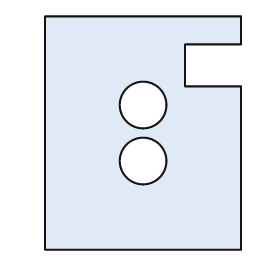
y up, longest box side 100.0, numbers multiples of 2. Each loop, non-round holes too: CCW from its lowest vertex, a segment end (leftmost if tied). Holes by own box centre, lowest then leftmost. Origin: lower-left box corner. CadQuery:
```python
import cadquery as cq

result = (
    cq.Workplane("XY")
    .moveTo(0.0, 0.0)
    .lineTo(84.0, 0.0)
    .lineTo(84.0, 70.0)
    .lineTo(60.0, 70.0)
    .lineTo(60.0, 88.0)
    .lineTo(84.0, 88.0)
    .lineTo(84.0, 100.0)
    .lineTo(0.0, 100.0)
    .close()
    .moveTo(42.0, 38.0)
    .circle(10.0)
    .moveTo(42.0, 62.0)
    .circle(10.0)
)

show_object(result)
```